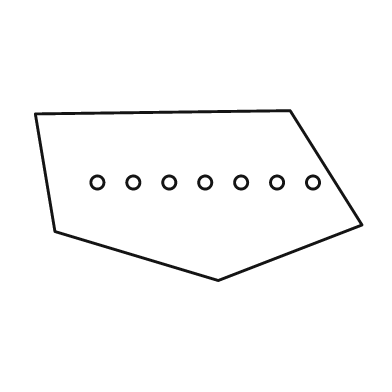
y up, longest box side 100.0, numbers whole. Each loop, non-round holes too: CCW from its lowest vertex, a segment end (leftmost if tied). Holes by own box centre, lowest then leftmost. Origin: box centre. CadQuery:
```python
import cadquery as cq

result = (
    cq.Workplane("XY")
    .moveTo(6.0, -26.0)
    .lineTo(50.0, -9.0)
    .lineTo(28.0, 26.0)
    .lineTo(-50.0, 25.0)
    .lineTo(-44.0, -11.0)
    .close()
    .moveTo(-31.0, 4.0)
    .circle(2.0)
    .moveTo(-20.0, 4.0)
    .circle(2.0)
    .moveTo(-9.0, 4.0)
    .circle(2.0)
    .moveTo(2.0, 4.0)
    .circle(2.0)
    .moveTo(13.0, 4.0)
    .circle(2.0)
    .moveTo(24.0, 4.0)
    .circle(2.0)
    .moveTo(35.0, 4.0)
    .circle(2.0)
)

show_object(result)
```